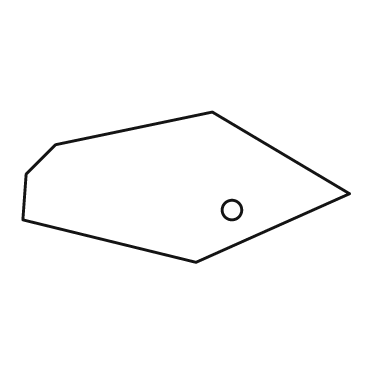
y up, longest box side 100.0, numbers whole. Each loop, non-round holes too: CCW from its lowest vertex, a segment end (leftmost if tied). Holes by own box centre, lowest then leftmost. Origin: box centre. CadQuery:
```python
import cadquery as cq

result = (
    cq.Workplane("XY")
    .moveTo(3.0, -23.0)
    .lineTo(50.0, -2.0)
    .lineTo(8.0, 23.0)
    .lineTo(-40.0, 13.0)
    .lineTo(-49.0, 4.0)
    .lineTo(-50.0, -10.0)
    .close()
    .moveTo(14.0, -7.0)
    .circle(3.0)
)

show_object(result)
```